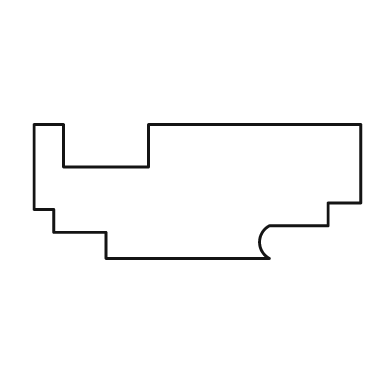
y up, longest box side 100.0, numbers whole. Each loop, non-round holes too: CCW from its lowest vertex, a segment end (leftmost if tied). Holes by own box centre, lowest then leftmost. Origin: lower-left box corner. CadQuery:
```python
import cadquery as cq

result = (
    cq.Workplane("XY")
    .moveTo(22.0, 0.0)
    .lineTo(72.0, 0.0)
    .threePointArc((69.0, 5.0), (72.0, 10.0))
    .lineTo(90.0, 10.0)
    .lineTo(90.0, 17.0)
    .lineTo(100.0, 17.0)
    .lineTo(100.0, 41.0)
    .lineTo(35.0, 41.0)
    .lineTo(35.0, 28.0)
    .lineTo(9.0, 28.0)
    .lineTo(9.0, 41.0)
    .lineTo(0.0, 41.0)
    .lineTo(0.0, 15.0)
    .lineTo(6.0, 15.0)
    .lineTo(6.0, 8.0)
    .lineTo(22.0, 8.0)
    .close()
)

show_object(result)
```